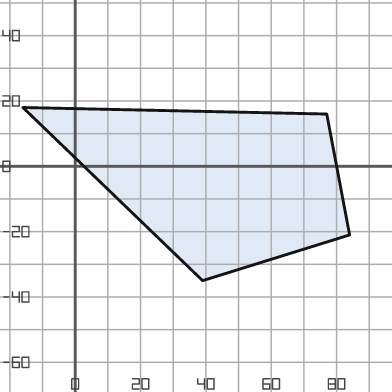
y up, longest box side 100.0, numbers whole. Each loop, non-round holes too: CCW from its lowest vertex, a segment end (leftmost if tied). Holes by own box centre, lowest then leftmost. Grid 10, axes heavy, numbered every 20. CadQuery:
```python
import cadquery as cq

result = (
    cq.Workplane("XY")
    .moveTo(39.0, -35.0)
    .lineTo(84.0, -21.0)
    .lineTo(77.0, 16.0)
    .lineTo(-16.0, 18.0)
    .close()
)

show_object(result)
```